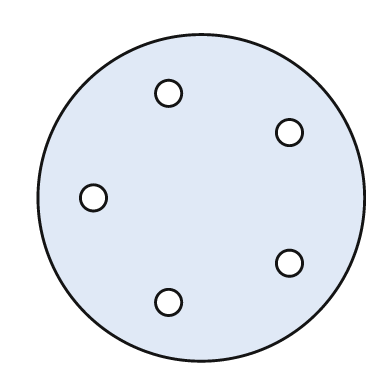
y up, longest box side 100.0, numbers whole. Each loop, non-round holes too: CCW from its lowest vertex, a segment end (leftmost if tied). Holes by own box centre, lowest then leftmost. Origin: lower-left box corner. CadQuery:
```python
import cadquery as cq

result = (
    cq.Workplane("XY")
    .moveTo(50.0, 50.0)
    .circle(50.0)
    .moveTo(40.0, 18.0)
    .circle(4.0)
    .moveTo(77.0, 30.0)
    .circle(4.0)
    .moveTo(17.0, 50.0)
    .circle(4.0)
    .moveTo(77.0, 70.0)
    .circle(4.0)
    .moveTo(40.0, 82.0)
    .circle(4.0)
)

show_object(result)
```